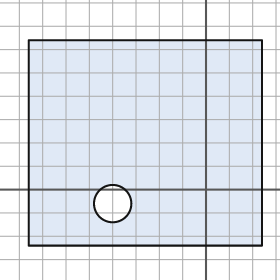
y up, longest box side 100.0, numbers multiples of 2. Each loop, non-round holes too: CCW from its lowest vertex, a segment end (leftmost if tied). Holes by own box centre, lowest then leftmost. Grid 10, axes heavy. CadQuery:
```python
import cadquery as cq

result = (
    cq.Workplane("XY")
    .moveTo(-76.0, -24.0)
    .lineTo(24.0, -24.0)
    .lineTo(24.0, 64.0)
    .lineTo(-76.0, 64.0)
    .close()
    .moveTo(-40.0, -6.0)
    .circle(8.0)
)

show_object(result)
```